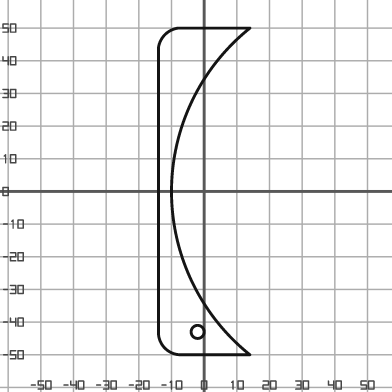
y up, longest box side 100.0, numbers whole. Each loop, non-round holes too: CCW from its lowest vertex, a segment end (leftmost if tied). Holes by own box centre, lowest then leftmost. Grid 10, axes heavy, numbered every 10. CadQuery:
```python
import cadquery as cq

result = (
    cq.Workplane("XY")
    .moveTo(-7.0, -50.0)
    .lineTo(14.0, -50.0)
    .threePointArc((-10.0, 0.0), (14.0, 50.0))
    .lineTo(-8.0, 50.0)
    .threePointArc((-12.0, 48.0), (-14.0, 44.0))
    .lineTo(-14.0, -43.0)
    .threePointArc((-12.0, -48.0), (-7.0, -50.0))
    .close()
    .moveTo(-2.0, -43.0)
    .circle(2.0)
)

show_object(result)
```